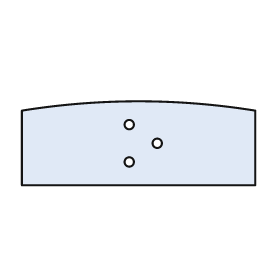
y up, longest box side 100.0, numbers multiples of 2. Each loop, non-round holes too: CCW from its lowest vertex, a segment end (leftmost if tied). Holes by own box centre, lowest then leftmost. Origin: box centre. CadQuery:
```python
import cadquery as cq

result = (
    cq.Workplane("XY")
    .moveTo(-50.0, -18.0)
    .lineTo(50.0, -18.0)
    .lineTo(50.0, 14.0)
    .threePointArc((0.0, 18.0), (-50.0, 14.0))
    .close()
    .moveTo(-4.0, -8.0)
    .circle(2.0)
    .moveTo(8.0, 0.0)
    .circle(2.0)
    .moveTo(-4.0, 8.0)
    .circle(2.0)
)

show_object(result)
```